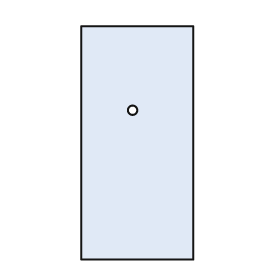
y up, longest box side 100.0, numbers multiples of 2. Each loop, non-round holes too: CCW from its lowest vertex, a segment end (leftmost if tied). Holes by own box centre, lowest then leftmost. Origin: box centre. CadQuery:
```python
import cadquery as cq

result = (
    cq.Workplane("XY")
    .moveTo(-24.0, -50.0)
    .lineTo(24.0, -50.0)
    .lineTo(24.0, 50.0)
    .lineTo(-24.0, 50.0)
    .close()
    .moveTo(-2.0, 14.0)
    .circle(2.0)
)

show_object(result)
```